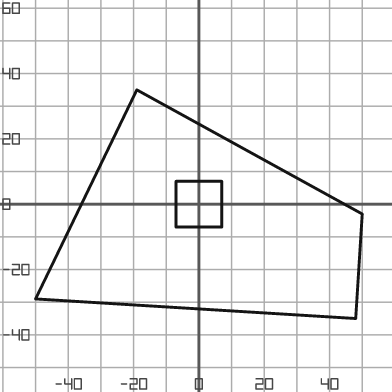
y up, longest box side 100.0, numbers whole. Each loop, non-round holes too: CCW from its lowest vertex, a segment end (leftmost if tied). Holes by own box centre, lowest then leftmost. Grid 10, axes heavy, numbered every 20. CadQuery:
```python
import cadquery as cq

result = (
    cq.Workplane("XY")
    .moveTo(48.0, -35.0)
    .lineTo(50.0, -3.0)
    .lineTo(-19.0, 35.0)
    .lineTo(-50.0, -29.0)
    .close()
    .moveTo(-7.0, -7.0)
    .lineTo(7.0, -7.0)
    .lineTo(7.0, 7.0)
    .lineTo(-7.0, 7.0)
    .close()
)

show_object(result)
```